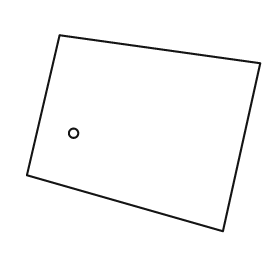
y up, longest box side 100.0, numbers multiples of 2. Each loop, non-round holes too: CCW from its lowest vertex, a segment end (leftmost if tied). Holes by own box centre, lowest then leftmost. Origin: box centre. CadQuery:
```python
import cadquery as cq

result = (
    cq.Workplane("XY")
    .moveTo(34.0, -42.0)
    .lineTo(50.0, 30.0)
    .lineTo(-36.0, 42.0)
    .lineTo(-50.0, -18.0)
    .close()
    .moveTo(-30.0, 0.0)
    .circle(2.0)
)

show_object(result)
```